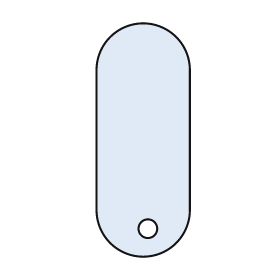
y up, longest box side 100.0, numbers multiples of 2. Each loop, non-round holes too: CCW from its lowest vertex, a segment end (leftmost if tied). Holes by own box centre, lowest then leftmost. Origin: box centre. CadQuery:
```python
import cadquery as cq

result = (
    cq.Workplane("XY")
    .moveTo(-20.0, -30.0)
    .threePointArc((0.0, -50.0), (20.0, -30.0))
    .lineTo(20.0, 30.0)
    .threePointArc((0.0, 50.0), (-20.0, 30.0))
    .close()
    .moveTo(2.0, -38.0)
    .circle(4.0)
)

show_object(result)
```